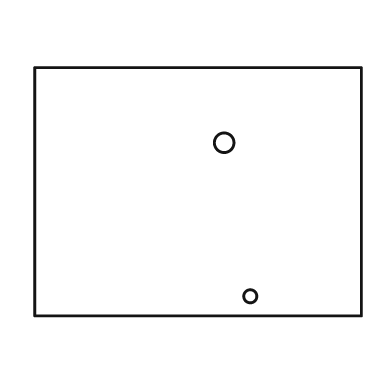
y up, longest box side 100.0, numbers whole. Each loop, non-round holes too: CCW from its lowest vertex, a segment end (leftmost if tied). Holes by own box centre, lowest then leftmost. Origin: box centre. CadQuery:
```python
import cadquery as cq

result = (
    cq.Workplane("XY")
    .moveTo(-50.0, -38.0)
    .lineTo(50.0, -38.0)
    .lineTo(50.0, 38.0)
    .lineTo(-50.0, 38.0)
    .close()
    .moveTo(16.0, -32.0)
    .circle(2.0)
    .moveTo(8.0, 15.0)
    .circle(3.0)
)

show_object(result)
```